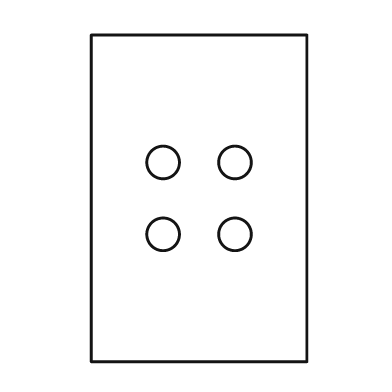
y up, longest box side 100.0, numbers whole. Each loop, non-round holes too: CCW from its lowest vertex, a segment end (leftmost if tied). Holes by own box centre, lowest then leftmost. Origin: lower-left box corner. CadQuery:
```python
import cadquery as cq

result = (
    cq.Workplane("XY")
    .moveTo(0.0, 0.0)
    .lineTo(66.0, 0.0)
    .lineTo(66.0, 100.0)
    .lineTo(0.0, 100.0)
    .close()
    .moveTo(22.0, 39.0)
    .circle(5.0)
    .moveTo(44.0, 39.0)
    .circle(5.0)
    .moveTo(22.0, 61.0)
    .circle(5.0)
    .moveTo(44.0, 61.0)
    .circle(5.0)
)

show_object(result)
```